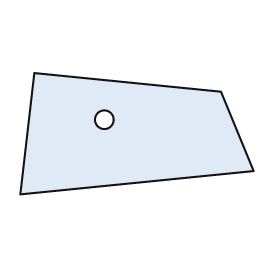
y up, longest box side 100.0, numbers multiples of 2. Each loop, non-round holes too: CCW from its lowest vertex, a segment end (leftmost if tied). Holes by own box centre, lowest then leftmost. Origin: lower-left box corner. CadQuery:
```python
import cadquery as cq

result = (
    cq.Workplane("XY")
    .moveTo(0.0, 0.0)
    .lineTo(100.0, 10.0)
    .lineTo(86.0, 44.0)
    .lineTo(6.0, 52.0)
    .close()
    .moveTo(36.0, 32.0)
    .circle(4.0)
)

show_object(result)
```